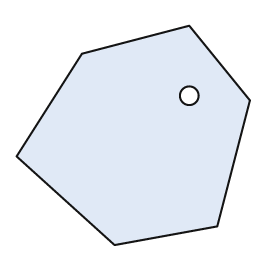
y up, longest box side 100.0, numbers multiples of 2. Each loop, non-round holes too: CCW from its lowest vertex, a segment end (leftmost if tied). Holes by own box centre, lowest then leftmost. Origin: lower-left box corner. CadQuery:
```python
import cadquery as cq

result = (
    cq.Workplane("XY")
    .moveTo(42.0, 0.0)
    .lineTo(86.0, 8.0)
    .lineTo(100.0, 62.0)
    .lineTo(74.0, 94.0)
    .lineTo(28.0, 82.0)
    .lineTo(0.0, 38.0)
    .close()
    .moveTo(74.0, 64.0)
    .circle(4.0)
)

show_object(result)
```